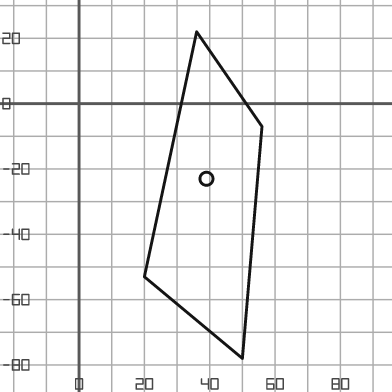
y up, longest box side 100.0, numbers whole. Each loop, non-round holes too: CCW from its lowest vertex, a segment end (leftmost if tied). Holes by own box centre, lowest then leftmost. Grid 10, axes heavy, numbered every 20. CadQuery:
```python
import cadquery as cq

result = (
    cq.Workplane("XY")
    .moveTo(50.0, -78.0)
    .lineTo(56.0, -7.0)
    .lineTo(36.0, 22.0)
    .lineTo(20.0, -53.0)
    .close()
    .moveTo(39.0, -23.0)
    .circle(2.0)
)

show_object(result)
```